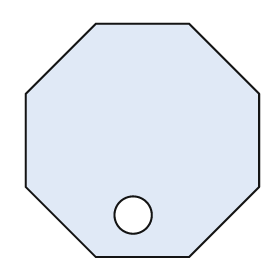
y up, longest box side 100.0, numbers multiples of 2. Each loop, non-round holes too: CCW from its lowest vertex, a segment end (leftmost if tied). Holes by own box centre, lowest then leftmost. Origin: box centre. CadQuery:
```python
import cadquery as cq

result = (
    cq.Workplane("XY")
    .moveTo(-20.0, -50.0)
    .lineTo(20.0, -50.0)
    .lineTo(50.0, -20.0)
    .lineTo(50.0, 20.0)
    .lineTo(20.0, 50.0)
    .lineTo(-20.0, 50.0)
    .lineTo(-50.0, 20.0)
    .lineTo(-50.0, -20.0)
    .close()
    .moveTo(-4.0, -32.0)
    .circle(8.0)
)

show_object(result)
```